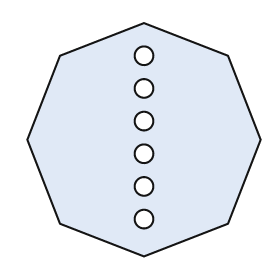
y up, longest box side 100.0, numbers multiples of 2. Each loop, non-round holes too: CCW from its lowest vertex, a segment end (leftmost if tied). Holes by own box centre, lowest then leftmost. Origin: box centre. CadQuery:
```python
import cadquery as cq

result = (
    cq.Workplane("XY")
    .moveTo(0.0, -50.0)
    .lineTo(36.0, -36.0)
    .lineTo(50.0, 0.0)
    .lineTo(36.0, 36.0)
    .lineTo(0.0, 50.0)
    .lineTo(-36.0, 36.0)
    .lineTo(-50.0, 0.0)
    .lineTo(-36.0, -36.0)
    .close()
    .moveTo(0.0, -34.0)
    .circle(4.0)
    .moveTo(0.0, -20.0)
    .circle(4.0)
    .moveTo(0.0, -6.0)
    .circle(4.0)
    .moveTo(0.0, 8.0)
    .circle(4.0)
    .moveTo(0.0, 22.0)
    .circle(4.0)
    .moveTo(0.0, 36.0)
    .circle(4.0)
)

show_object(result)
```